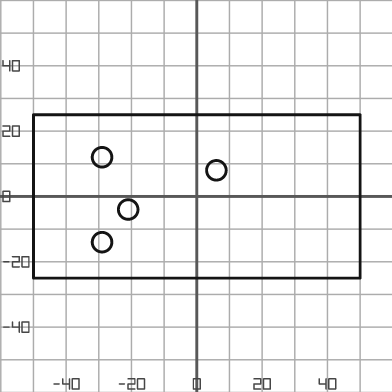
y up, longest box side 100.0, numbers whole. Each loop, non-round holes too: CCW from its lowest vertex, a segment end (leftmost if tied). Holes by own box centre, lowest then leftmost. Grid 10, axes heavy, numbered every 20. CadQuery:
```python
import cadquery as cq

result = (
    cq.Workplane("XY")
    .moveTo(-50.0, -25.0)
    .lineTo(50.0, -25.0)
    .lineTo(50.0, 25.0)
    .lineTo(-50.0, 25.0)
    .close()
    .moveTo(-29.0, -14.0)
    .circle(3.0)
    .moveTo(-21.0, -4.0)
    .circle(3.0)
    .moveTo(6.0, 8.0)
    .circle(3.0)
    .moveTo(-29.0, 12.0)
    .circle(3.0)
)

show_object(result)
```